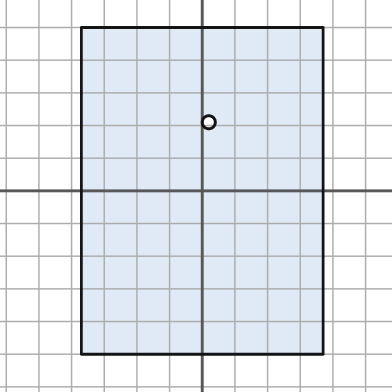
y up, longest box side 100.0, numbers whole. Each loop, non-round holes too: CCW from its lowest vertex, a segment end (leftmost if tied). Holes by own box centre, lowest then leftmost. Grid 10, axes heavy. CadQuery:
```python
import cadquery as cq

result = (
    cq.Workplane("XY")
    .moveTo(-37.0, -50.0)
    .lineTo(37.0, -50.0)
    .lineTo(37.0, 50.0)
    .lineTo(-37.0, 50.0)
    .close()
    .moveTo(2.0, 21.0)
    .circle(2.0)
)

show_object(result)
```